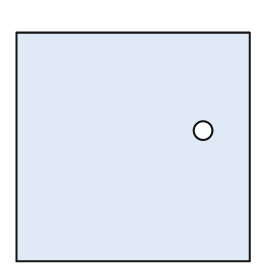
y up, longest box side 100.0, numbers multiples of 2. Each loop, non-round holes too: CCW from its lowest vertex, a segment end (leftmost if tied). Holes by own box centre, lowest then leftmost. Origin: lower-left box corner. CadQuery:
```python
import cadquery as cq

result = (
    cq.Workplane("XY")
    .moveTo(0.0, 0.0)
    .lineTo(100.0, 0.0)
    .lineTo(100.0, 98.0)
    .lineTo(0.0, 98.0)
    .close()
    .moveTo(80.0, 56.0)
    .circle(4.0)
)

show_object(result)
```